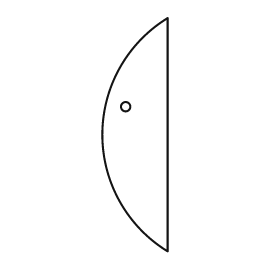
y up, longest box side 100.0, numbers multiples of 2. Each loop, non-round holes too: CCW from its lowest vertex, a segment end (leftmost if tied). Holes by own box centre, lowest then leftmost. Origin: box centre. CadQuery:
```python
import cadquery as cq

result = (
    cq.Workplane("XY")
    .moveTo(14.0, -50.0)
    .lineTo(14.0, 50.0)
    .threePointArc((-14.0, 0.0), (14.0, -50.0))
    .close()
    .moveTo(-4.0, 12.0)
    .circle(2.0)
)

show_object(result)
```